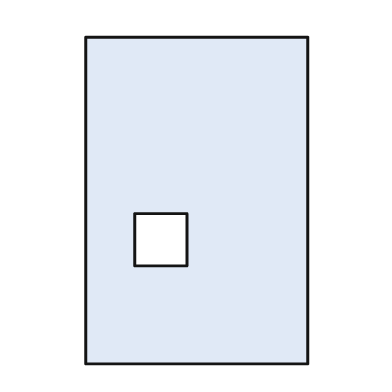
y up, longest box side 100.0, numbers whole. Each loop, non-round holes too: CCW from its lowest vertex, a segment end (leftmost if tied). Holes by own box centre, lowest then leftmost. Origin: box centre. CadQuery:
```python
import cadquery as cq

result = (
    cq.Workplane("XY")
    .moveTo(-34.0, -50.0)
    .lineTo(34.0, -50.0)
    .lineTo(34.0, 50.0)
    .lineTo(-34.0, 50.0)
    .close()
    .moveTo(-19.0, -20.0)
    .lineTo(-3.0, -20.0)
    .lineTo(-3.0, -4.0)
    .lineTo(-19.0, -4.0)
    .close()
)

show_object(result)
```